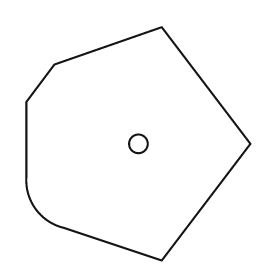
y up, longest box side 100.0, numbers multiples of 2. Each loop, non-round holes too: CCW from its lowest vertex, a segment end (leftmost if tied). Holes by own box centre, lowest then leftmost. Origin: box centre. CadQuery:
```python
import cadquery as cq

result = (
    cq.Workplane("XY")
    .moveTo(10.0, -50.0)
    .lineTo(48.0, 0.0)
    .lineTo(10.0, 50.0)
    .lineTo(-36.0, 34.0)
    .lineTo(-48.0, 18.0)
    .lineTo(-48.0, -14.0)
    .threePointArc((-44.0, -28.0), (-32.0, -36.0))
    .close()
    .moveTo(0.0, 0.0)
    .circle(4.0)
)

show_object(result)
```